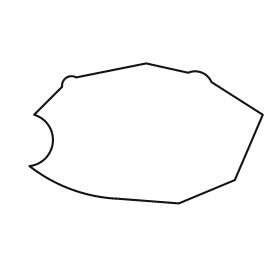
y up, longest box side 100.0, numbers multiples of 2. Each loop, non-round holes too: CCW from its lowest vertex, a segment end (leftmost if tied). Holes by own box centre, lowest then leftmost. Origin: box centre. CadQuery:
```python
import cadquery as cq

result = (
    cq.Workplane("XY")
    .moveTo(14.0, -30.0)
    .lineTo(38.0, -20.0)
    .lineTo(50.0, 8.0)
    .lineTo(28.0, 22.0)
    .threePointArc((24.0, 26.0), (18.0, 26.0))
    .lineTo(0.0, 30.0)
    .lineTo(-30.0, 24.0)
    .threePointArc((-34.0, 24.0), (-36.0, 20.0))
    .lineTo(-48.0, 8.0)
    .threePointArc((-40.0, -4.0), (-50.0, -14.0))
    .threePointArc((-32.0, -24.0), (-12.0, -28.0))
    .close()
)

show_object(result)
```